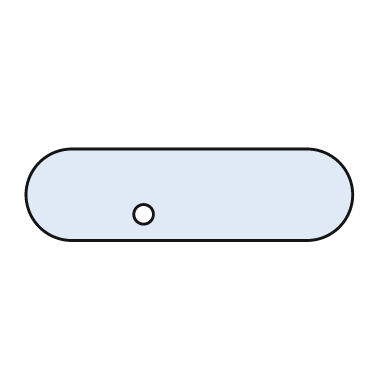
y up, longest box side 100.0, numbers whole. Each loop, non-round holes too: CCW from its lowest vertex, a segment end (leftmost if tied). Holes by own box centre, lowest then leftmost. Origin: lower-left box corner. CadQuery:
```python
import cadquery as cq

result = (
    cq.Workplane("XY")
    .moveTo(14.0, 0.0)
    .lineTo(86.0, 0.0)
    .threePointArc((100.0, 14.0), (86.0, 28.0))
    .lineTo(14.0, 28.0)
    .threePointArc((0.0, 14.0), (14.0, 0.0))
    .close()
    .moveTo(36.0, 8.0)
    .circle(3.0)
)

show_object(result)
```